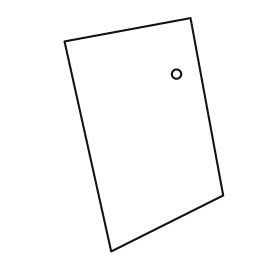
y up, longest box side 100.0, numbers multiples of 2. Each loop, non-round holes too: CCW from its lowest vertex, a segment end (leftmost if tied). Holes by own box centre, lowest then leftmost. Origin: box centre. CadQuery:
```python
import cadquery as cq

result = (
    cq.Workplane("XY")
    .moveTo(-14.0, -50.0)
    .lineTo(34.0, -26.0)
    .lineTo(20.0, 50.0)
    .lineTo(-34.0, 40.0)
    .close()
    .moveTo(14.0, 26.0)
    .circle(2.0)
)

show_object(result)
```